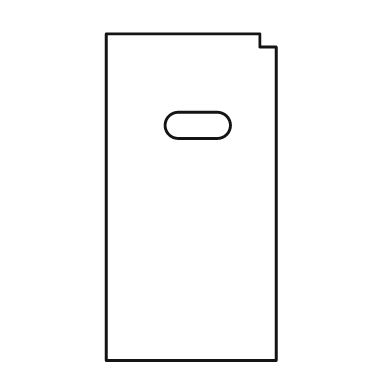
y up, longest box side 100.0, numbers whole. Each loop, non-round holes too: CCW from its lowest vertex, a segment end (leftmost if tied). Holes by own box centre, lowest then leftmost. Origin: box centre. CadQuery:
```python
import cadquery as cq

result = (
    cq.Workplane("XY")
    .moveTo(-26.0, -50.0)
    .lineTo(26.0, -50.0)
    .lineTo(26.0, 46.0)
    .lineTo(21.0, 46.0)
    .lineTo(21.0, 50.0)
    .lineTo(-26.0, 50.0)
    .close()
    .moveTo(-4.0, 18.0)
    .lineTo(8.0, 18.0)
    .threePointArc((12.0, 22.0), (8.0, 26.0))
    .lineTo(-4.0, 26.0)
    .threePointArc((-8.0, 22.0), (-4.0, 18.0))
    .close()
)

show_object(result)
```